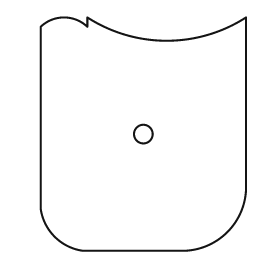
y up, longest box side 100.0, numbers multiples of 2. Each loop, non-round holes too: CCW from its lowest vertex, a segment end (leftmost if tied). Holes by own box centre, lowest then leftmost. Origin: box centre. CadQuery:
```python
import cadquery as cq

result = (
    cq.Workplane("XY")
    .moveTo(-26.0, -50.0)
    .lineTo(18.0, -50.0)
    .threePointArc((36.0, -42.0), (44.0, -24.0))
    .lineTo(44.0, 50.0)
    .threePointArc((10.0, 40.0), (-24.0, 50.0))
    .lineTo(-24.0, 46.0)
    .threePointArc((-34.0, 50.0), (-44.0, 46.0))
    .lineTo(-44.0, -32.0)
    .threePointArc((-38.0, -44.0), (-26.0, -50.0))
    .close()
    .moveTo(0.0, 0.0)
    .circle(4.0)
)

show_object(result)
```